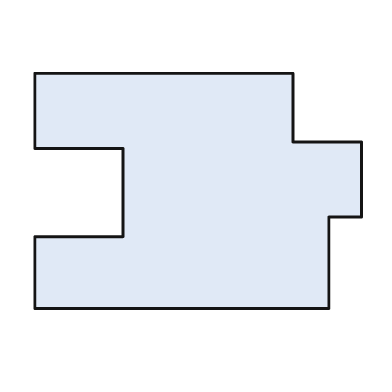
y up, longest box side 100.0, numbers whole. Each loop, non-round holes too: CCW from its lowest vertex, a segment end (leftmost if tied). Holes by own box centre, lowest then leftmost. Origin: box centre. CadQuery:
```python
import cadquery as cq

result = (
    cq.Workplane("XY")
    .moveTo(-50.0, -36.0)
    .lineTo(40.0, -36.0)
    .lineTo(40.0, -8.0)
    .lineTo(50.0, -8.0)
    .lineTo(50.0, 15.0)
    .lineTo(29.0, 15.0)
    .lineTo(29.0, 36.0)
    .lineTo(-50.0, 36.0)
    .lineTo(-50.0, 13.0)
    .lineTo(-23.0, 13.0)
    .lineTo(-23.0, -14.0)
    .lineTo(-50.0, -14.0)
    .close()
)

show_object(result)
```